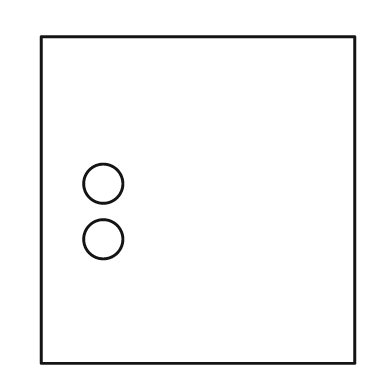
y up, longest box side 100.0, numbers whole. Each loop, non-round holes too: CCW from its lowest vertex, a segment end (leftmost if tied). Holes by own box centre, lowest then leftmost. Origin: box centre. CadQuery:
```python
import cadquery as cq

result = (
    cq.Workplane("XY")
    .moveTo(-48.0, -50.0)
    .lineTo(48.0, -50.0)
    .lineTo(48.0, 50.0)
    .lineTo(-48.0, 50.0)
    .close()
    .moveTo(-29.0, -12.0)
    .circle(6.0)
    .moveTo(-29.0, 5.0)
    .circle(6.0)
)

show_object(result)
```